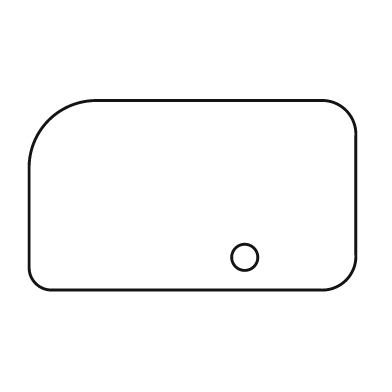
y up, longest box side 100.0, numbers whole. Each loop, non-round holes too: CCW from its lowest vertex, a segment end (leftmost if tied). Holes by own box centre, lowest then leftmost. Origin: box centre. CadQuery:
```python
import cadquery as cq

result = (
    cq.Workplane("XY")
    .moveTo(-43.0, -29.0)
    .lineTo(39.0, -29.0)
    .threePointArc((47.0, -26.0), (50.0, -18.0))
    .lineTo(50.0, 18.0)
    .threePointArc((47.0, 26.0), (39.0, 29.0))
    .lineTo(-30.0, 29.0)
    .threePointArc((-44.0, 23.0), (-50.0, 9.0))
    .lineTo(-50.0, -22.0)
    .threePointArc((-48.0, -27.0), (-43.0, -29.0))
    .close()
    .moveTo(16.0, -19.0)
    .circle(4.0)
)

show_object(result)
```